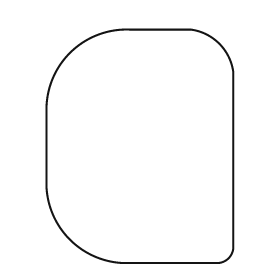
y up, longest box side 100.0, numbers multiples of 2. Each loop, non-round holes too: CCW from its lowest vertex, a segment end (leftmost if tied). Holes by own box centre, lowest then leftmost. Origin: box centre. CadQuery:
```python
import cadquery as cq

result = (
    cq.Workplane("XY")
    .moveTo(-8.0, -50.0)
    .lineTo(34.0, -50.0)
    .threePointArc((38.0, -48.0), (40.0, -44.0))
    .lineTo(40.0, 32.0)
    .threePointArc((34.0, 44.0), (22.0, 50.0))
    .lineTo(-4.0, 50.0)
    .threePointArc((-30.0, 40.0), (-40.0, 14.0))
    .lineTo(-40.0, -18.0)
    .threePointArc((-30.0, -40.0), (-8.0, -50.0))
    .close()
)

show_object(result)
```